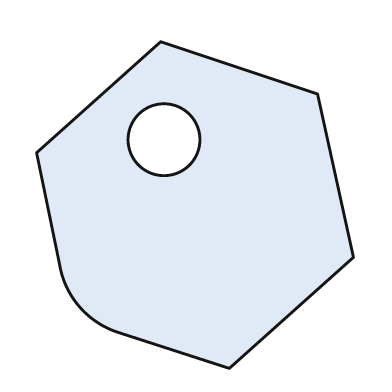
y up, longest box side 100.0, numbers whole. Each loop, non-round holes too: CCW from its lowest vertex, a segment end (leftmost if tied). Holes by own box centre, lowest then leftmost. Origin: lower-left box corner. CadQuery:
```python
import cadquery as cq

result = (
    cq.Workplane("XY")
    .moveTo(59.0, 0.0)
    .lineTo(97.0, 34.0)
    .lineTo(86.0, 84.0)
    .lineTo(38.0, 100.0)
    .lineTo(0.0, 66.0)
    .lineTo(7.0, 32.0)
    .threePointArc((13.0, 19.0), (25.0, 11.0))
    .close()
    .moveTo(39.0, 70.0)
    .circle(11.0)
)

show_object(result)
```